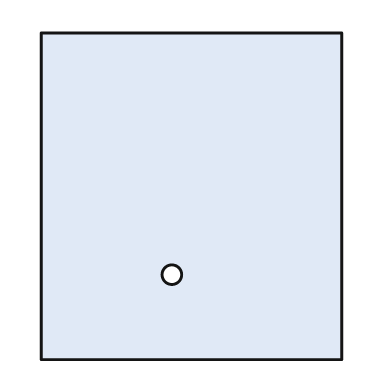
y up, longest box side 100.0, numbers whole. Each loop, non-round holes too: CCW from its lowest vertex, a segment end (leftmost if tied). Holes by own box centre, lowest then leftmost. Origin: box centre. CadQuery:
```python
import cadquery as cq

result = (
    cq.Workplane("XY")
    .moveTo(-46.0, -50.0)
    .lineTo(46.0, -50.0)
    .lineTo(46.0, 50.0)
    .lineTo(-46.0, 50.0)
    .close()
    .moveTo(-6.0, -24.0)
    .circle(3.0)
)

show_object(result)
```